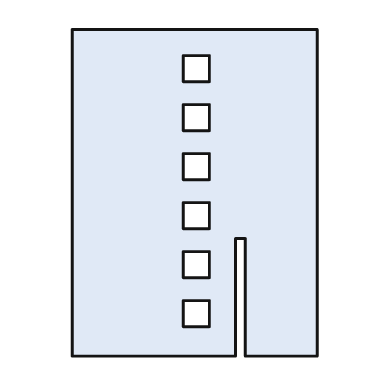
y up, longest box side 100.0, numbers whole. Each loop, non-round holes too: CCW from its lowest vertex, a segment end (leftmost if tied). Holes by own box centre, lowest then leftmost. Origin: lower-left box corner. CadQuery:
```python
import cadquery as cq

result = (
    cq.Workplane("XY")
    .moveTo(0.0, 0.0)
    .lineTo(50.0, 0.0)
    .lineTo(50.0, 36.0)
    .lineTo(53.0, 36.0)
    .lineTo(53.0, 0.0)
    .lineTo(75.0, 0.0)
    .lineTo(75.0, 100.0)
    .lineTo(0.0, 100.0)
    .close()
    .moveTo(34.0, 9.0)
    .lineTo(42.0, 9.0)
    .lineTo(42.0, 17.0)
    .lineTo(34.0, 17.0)
    .close()
    .moveTo(34.0, 24.0)
    .lineTo(42.0, 24.0)
    .lineTo(42.0, 32.0)
    .lineTo(34.0, 32.0)
    .close()
    .moveTo(34.0, 39.0)
    .lineTo(42.0, 39.0)
    .lineTo(42.0, 47.0)
    .lineTo(34.0, 47.0)
    .close()
    .moveTo(34.0, 54.0)
    .lineTo(42.0, 54.0)
    .lineTo(42.0, 62.0)
    .lineTo(34.0, 62.0)
    .close()
    .moveTo(34.0, 69.0)
    .lineTo(42.0, 69.0)
    .lineTo(42.0, 77.0)
    .lineTo(34.0, 77.0)
    .close()
    .moveTo(34.0, 84.0)
    .lineTo(42.0, 84.0)
    .lineTo(42.0, 92.0)
    .lineTo(34.0, 92.0)
    .close()
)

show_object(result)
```